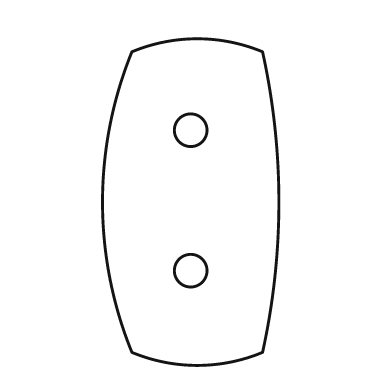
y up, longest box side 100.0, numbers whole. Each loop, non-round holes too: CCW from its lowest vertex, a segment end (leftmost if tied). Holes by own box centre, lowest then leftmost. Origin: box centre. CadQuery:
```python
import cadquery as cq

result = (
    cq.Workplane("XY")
    .moveTo(-18.0, -46.0)
    .threePointArc((2.0, -50.0), (22.0, -46.0))
    .threePointArc((27.0, 0.0), (22.0, 46.0))
    .threePointArc((2.0, 50.0), (-18.0, 46.0))
    .threePointArc((-27.0, 0.0), (-18.0, -46.0))
    .close()
    .moveTo(0.0, -21.0)
    .circle(5.0)
    .moveTo(0.0, 22.0)
    .circle(5.0)
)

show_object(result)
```